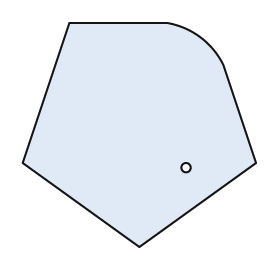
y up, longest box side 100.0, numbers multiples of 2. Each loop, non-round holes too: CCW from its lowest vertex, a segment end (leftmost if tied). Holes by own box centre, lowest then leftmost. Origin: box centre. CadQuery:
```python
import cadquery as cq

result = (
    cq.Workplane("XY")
    .moveTo(0.0, -48.0)
    .lineTo(50.0, -12.0)
    .lineTo(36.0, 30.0)
    .threePointArc((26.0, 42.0), (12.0, 48.0))
    .lineTo(-30.0, 48.0)
    .lineTo(-50.0, -12.0)
    .close()
    .moveTo(20.0, -14.0)
    .circle(2.0)
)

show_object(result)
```